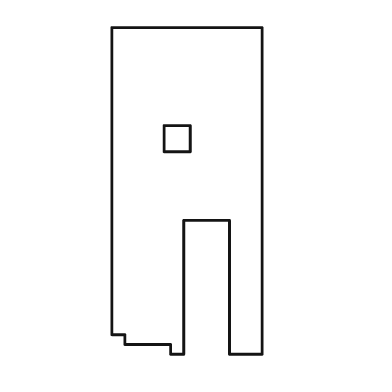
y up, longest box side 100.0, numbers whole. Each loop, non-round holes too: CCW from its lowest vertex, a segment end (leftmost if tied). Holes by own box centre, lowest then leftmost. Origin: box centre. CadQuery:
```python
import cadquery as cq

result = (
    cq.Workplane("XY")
    .moveTo(-5.0, -50.0)
    .lineTo(-1.0, -50.0)
    .lineTo(-1.0, -9.0)
    .lineTo(13.0, -9.0)
    .lineTo(13.0, -50.0)
    .lineTo(23.0, -50.0)
    .lineTo(23.0, 50.0)
    .lineTo(-23.0, 50.0)
    .lineTo(-23.0, -44.0)
    .lineTo(-19.0, -44.0)
    .lineTo(-19.0, -47.0)
    .lineTo(-5.0, -47.0)
    .close()
    .moveTo(-7.0, 12.0)
    .lineTo(1.0, 12.0)
    .lineTo(1.0, 20.0)
    .lineTo(-7.0, 20.0)
    .close()
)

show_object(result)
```